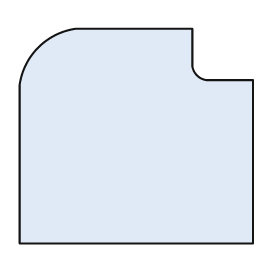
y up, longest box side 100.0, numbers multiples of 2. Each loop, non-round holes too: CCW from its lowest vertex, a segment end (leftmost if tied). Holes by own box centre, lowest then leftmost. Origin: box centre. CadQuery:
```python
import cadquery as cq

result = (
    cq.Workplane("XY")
    .moveTo(-50.0, -46.0)
    .lineTo(50.0, -46.0)
    .lineTo(50.0, 24.0)
    .lineTo(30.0, 24.0)
    .threePointArc((26.0, 26.0), (24.0, 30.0))
    .lineTo(24.0, 46.0)
    .lineTo(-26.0, 46.0)
    .threePointArc((-42.0, 38.0), (-50.0, 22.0))
    .close()
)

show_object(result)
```